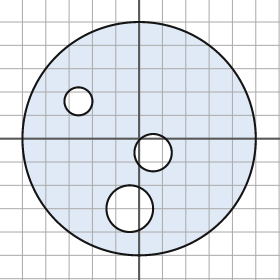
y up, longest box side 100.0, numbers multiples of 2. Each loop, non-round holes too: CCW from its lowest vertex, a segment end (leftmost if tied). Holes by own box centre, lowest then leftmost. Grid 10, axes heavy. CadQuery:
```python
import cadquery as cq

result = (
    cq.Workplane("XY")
    .moveTo(0.0, 0.0)
    .circle(50.0)
    .moveTo(-4.0, -30.0)
    .circle(10.0)
    .moveTo(6.0, -6.0)
    .circle(8.0)
    .moveTo(-26.0, 16.0)
    .circle(6.0)
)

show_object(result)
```